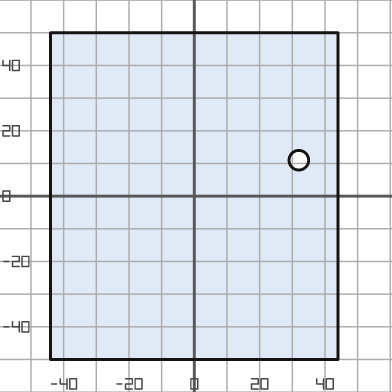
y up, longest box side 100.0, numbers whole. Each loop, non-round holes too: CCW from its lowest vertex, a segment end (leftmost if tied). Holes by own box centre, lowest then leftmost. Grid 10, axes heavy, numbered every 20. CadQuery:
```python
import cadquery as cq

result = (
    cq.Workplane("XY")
    .moveTo(-44.0, -50.0)
    .lineTo(44.0, -50.0)
    .lineTo(44.0, 50.0)
    .lineTo(-44.0, 50.0)
    .close()
    .moveTo(32.0, 11.0)
    .circle(3.0)
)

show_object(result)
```